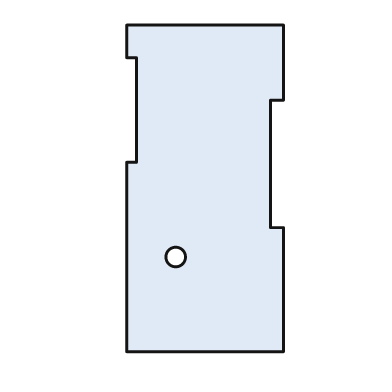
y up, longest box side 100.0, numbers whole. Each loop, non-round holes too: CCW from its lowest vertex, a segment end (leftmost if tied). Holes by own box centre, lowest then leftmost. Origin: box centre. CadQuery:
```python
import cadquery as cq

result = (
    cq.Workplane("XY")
    .moveTo(-24.0, -50.0)
    .lineTo(24.0, -50.0)
    .lineTo(24.0, -12.0)
    .lineTo(20.0, -12.0)
    .lineTo(20.0, 27.0)
    .lineTo(24.0, 27.0)
    .lineTo(24.0, 50.0)
    .lineTo(-24.0, 50.0)
    .lineTo(-24.0, 40.0)
    .lineTo(-21.0, 40.0)
    .lineTo(-21.0, 8.0)
    .lineTo(-24.0, 8.0)
    .close()
    .moveTo(-9.0, -21.0)
    .circle(3.0)
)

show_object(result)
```